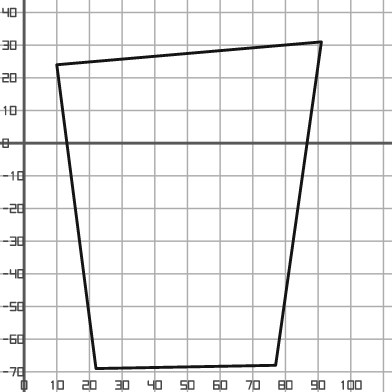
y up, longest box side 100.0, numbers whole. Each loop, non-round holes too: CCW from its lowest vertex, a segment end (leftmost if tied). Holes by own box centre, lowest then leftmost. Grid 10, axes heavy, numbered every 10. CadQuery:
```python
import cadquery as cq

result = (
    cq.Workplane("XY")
    .moveTo(22.0, -69.0)
    .lineTo(77.0, -68.0)
    .lineTo(91.0, 31.0)
    .lineTo(10.0, 24.0)
    .close()
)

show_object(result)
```